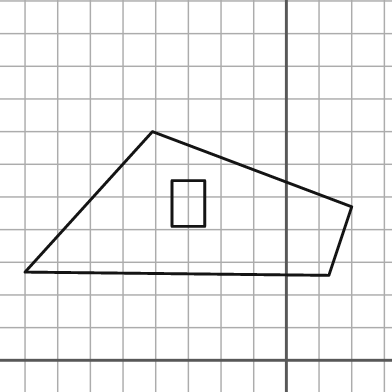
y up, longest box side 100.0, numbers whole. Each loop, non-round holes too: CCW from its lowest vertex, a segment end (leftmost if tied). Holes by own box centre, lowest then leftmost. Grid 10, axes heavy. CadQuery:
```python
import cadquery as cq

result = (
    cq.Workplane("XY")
    .moveTo(13.0, 26.0)
    .lineTo(20.0, 47.0)
    .lineTo(-41.0, 70.0)
    .lineTo(-80.0, 27.0)
    .close()
    .moveTo(-35.0, 41.0)
    .lineTo(-25.0, 41.0)
    .lineTo(-25.0, 55.0)
    .lineTo(-35.0, 55.0)
    .close()
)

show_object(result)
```